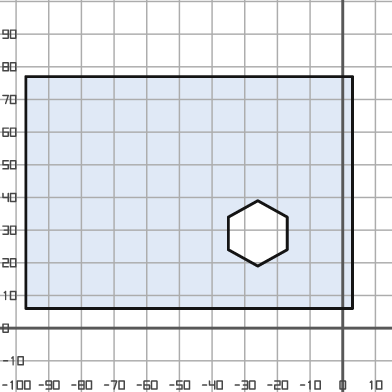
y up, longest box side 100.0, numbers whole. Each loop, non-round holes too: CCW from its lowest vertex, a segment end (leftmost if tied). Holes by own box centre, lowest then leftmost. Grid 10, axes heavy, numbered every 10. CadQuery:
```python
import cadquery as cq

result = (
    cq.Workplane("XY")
    .moveTo(-97.0, 6.0)
    .lineTo(3.0, 6.0)
    .lineTo(3.0, 77.0)
    .lineTo(-97.0, 77.0)
    .close()
    .moveTo(-26.0, 19.0)
    .lineTo(-17.0, 24.0)
    .lineTo(-17.0, 34.0)
    .lineTo(-26.0, 39.0)
    .lineTo(-35.0, 34.0)
    .lineTo(-35.0, 24.0)
    .close()
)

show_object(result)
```